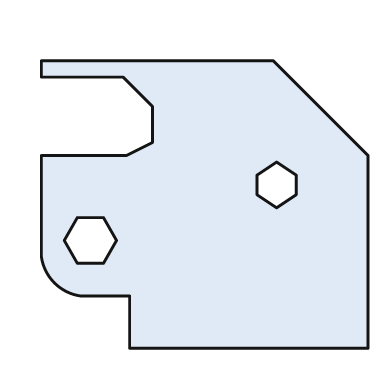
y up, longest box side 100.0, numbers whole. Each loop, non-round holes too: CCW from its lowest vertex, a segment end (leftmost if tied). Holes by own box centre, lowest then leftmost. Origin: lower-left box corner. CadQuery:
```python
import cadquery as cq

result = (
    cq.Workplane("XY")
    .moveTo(27.0, 0.0)
    .lineTo(100.0, 0.0)
    .lineTo(100.0, 59.0)
    .lineTo(71.0, 88.0)
    .lineTo(0.0, 88.0)
    .lineTo(0.0, 83.0)
    .lineTo(25.0, 83.0)
    .lineTo(34.0, 74.0)
    .lineTo(34.0, 63.0)
    .lineTo(26.0, 59.0)
    .lineTo(0.0, 59.0)
    .lineTo(0.0, 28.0)
    .threePointArc((4.0, 20.0), (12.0, 16.0))
    .lineTo(27.0, 16.0)
    .close()
    .moveTo(11.0, 26.0)
    .lineTo(19.0, 26.0)
    .lineTo(23.0, 33.0)
    .lineTo(19.0, 40.0)
    .lineTo(11.0, 40.0)
    .lineTo(7.0, 33.0)
    .close()
    .moveTo(72.0, 43.0)
    .lineTo(78.0, 47.0)
    .lineTo(78.0, 53.0)
    .lineTo(72.0, 57.0)
    .lineTo(66.0, 53.0)
    .lineTo(66.0, 47.0)
    .close()
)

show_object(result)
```